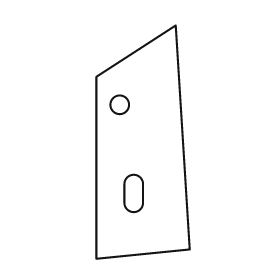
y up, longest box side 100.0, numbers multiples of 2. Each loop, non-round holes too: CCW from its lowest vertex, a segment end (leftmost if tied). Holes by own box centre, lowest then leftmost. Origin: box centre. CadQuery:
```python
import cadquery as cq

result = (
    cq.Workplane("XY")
    .moveTo(-20.0, -50.0)
    .lineTo(20.0, -46.0)
    .lineTo(14.0, 50.0)
    .lineTo(-20.0, 28.0)
    .close()
    .moveTo(-8.0, -26.0)
    .threePointArc((-4.0, -30.0), (0.0, -26.0))
    .lineTo(0.0, -18.0)
    .threePointArc((-4.0, -14.0), (-8.0, -18.0))
    .close()
    .moveTo(-10.0, 16.0)
    .circle(4.0)
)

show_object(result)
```